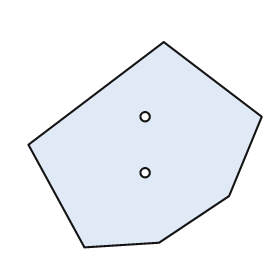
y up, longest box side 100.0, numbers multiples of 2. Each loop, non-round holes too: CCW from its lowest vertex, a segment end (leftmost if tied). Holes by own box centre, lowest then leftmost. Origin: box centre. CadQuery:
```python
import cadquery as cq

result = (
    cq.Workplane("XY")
    .moveTo(-26.0, -44.0)
    .lineTo(6.0, -42.0)
    .lineTo(36.0, -22.0)
    .lineTo(50.0, 12.0)
    .lineTo(8.0, 44.0)
    .lineTo(-50.0, 0.0)
    .close()
    .moveTo(0.0, -12.0)
    .circle(2.0)
    .moveTo(0.0, 12.0)
    .circle(2.0)
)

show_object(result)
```